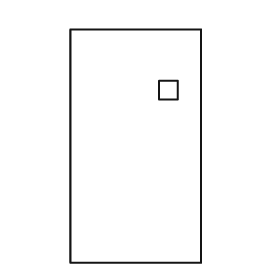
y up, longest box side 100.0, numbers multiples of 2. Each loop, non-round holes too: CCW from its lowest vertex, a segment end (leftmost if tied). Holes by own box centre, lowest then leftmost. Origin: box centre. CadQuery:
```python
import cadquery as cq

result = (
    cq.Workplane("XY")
    .moveTo(-28.0, -50.0)
    .lineTo(28.0, -50.0)
    .lineTo(28.0, 50.0)
    .lineTo(-28.0, 50.0)
    .close()
    .moveTo(10.0, 20.0)
    .lineTo(18.0, 20.0)
    .lineTo(18.0, 28.0)
    .lineTo(10.0, 28.0)
    .close()
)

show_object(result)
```